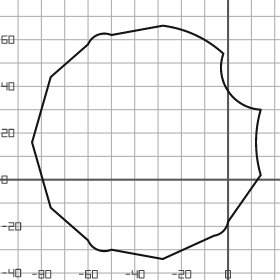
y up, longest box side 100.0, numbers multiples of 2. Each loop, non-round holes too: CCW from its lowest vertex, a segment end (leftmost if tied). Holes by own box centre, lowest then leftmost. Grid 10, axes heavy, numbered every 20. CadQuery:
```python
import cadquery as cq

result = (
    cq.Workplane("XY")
    .moveTo(-28.0, -34.0)
    .lineTo(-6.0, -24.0)
    .threePointArc((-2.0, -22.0), (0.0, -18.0))
    .lineTo(14.0, 2.0)
    .threePointArc((12.0, 16.0), (14.0, 30.0))
    .threePointArc((0.0, 38.0), (-2.0, 54.0))
    .threePointArc((-14.0, 62.0), (-28.0, 66.0))
    .lineTo(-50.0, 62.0)
    .threePointArc((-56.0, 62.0), (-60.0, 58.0))
    .lineTo(-76.0, 44.0)
    .lineTo(-84.0, 16.0)
    .lineTo(-76.0, -12.0)
    .lineTo(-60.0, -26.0)
    .threePointArc((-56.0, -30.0), (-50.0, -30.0))
    .close()
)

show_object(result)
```